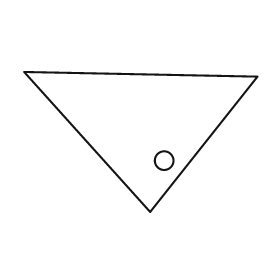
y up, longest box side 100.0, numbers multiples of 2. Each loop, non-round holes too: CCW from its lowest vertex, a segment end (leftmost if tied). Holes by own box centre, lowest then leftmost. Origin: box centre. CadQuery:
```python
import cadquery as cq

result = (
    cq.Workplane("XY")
    .moveTo(4.0, -30.0)
    .lineTo(50.0, 28.0)
    .lineTo(-50.0, 30.0)
    .close()
    .moveTo(10.0, -8.0)
    .circle(4.0)
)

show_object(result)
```